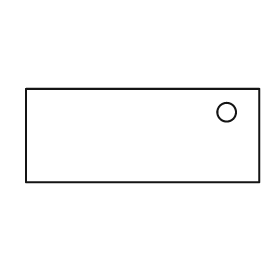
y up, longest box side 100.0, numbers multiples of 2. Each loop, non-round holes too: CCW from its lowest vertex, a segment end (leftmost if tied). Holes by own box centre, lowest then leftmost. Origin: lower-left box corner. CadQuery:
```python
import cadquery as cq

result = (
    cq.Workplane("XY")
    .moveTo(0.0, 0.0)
    .lineTo(100.0, 0.0)
    .lineTo(100.0, 40.0)
    .lineTo(0.0, 40.0)
    .close()
    .moveTo(86.0, 30.0)
    .circle(4.0)
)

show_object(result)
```